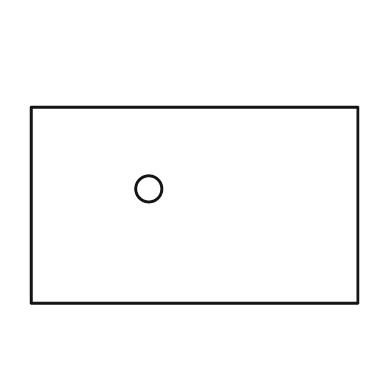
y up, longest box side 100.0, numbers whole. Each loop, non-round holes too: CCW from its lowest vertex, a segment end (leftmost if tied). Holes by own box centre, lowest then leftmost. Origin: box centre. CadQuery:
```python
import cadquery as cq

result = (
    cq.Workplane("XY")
    .moveTo(-50.0, -30.0)
    .lineTo(50.0, -30.0)
    .lineTo(50.0, 30.0)
    .lineTo(-50.0, 30.0)
    .close()
    .moveTo(-14.0, 5.0)
    .circle(4.0)
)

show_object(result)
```